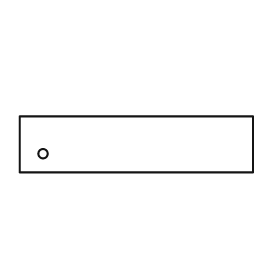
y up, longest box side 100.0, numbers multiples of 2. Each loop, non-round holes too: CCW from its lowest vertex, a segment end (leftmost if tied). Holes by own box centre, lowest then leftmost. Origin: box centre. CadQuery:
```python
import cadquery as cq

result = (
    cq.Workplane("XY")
    .moveTo(-50.0, -12.0)
    .lineTo(50.0, -12.0)
    .lineTo(50.0, 12.0)
    .lineTo(-50.0, 12.0)
    .close()
    .moveTo(-40.0, -4.0)
    .circle(2.0)
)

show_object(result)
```